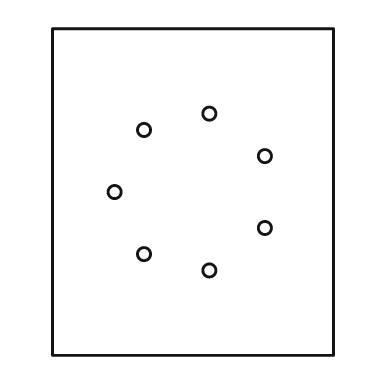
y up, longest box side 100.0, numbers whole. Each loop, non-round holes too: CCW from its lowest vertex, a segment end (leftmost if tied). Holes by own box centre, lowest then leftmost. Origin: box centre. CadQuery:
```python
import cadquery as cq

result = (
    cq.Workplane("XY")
    .moveTo(-43.0, -50.0)
    .lineTo(43.0, -50.0)
    .lineTo(43.0, 50.0)
    .lineTo(-43.0, 50.0)
    .close()
    .moveTo(5.0, -24.0)
    .circle(2.0)
    .moveTo(-15.0, -19.0)
    .circle(2.0)
    .moveTo(22.0, -11.0)
    .circle(2.0)
    .moveTo(-24.0, 0.0)
    .circle(2.0)
    .moveTo(22.0, 11.0)
    .circle(2.0)
    .moveTo(-15.0, 19.0)
    .circle(2.0)
    .moveTo(5.0, 24.0)
    .circle(2.0)
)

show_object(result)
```